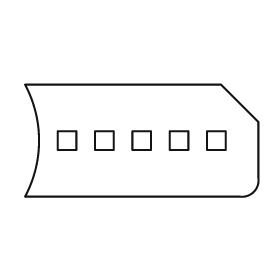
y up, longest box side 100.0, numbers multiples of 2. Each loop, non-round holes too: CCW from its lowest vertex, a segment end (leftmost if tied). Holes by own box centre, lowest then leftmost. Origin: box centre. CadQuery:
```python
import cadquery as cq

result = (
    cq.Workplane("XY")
    .moveTo(-50.0, -24.0)
    .lineTo(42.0, -24.0)
    .threePointArc((48.0, -22.0), (50.0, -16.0))
    .lineTo(50.0, 8.0)
    .lineTo(34.0, 24.0)
    .lineTo(-50.0, 24.0)
    .threePointArc((-44.0, 0.0), (-50.0, -24.0))
    .close()
    .moveTo(-36.0, -4.0)
    .lineTo(-28.0, -4.0)
    .lineTo(-28.0, 4.0)
    .lineTo(-36.0, 4.0)
    .close()
    .moveTo(-20.0, -4.0)
    .lineTo(-12.0, -4.0)
    .lineTo(-12.0, 4.0)
    .lineTo(-20.0, 4.0)
    .close()
    .moveTo(-4.0, -4.0)
    .lineTo(4.0, -4.0)
    .lineTo(4.0, 4.0)
    .lineTo(-4.0, 4.0)
    .close()
    .moveTo(12.0, -4.0)
    .lineTo(20.0, -4.0)
    .lineTo(20.0, 4.0)
    .lineTo(12.0, 4.0)
    .close()
    .moveTo(28.0, -4.0)
    .lineTo(36.0, -4.0)
    .lineTo(36.0, 4.0)
    .lineTo(28.0, 4.0)
    .close()
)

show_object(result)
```